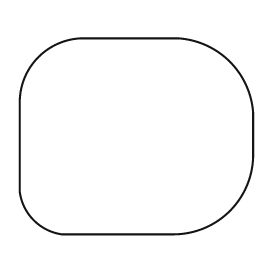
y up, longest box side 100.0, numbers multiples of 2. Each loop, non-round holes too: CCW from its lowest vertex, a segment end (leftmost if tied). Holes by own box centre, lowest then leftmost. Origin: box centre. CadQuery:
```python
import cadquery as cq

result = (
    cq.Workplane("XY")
    .moveTo(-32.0, -42.0)
    .lineTo(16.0, -42.0)
    .threePointArc((40.0, -32.0), (50.0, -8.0))
    .lineTo(50.0, 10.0)
    .threePointArc((40.0, 32.0), (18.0, 42.0))
    .lineTo(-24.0, 42.0)
    .threePointArc((-42.0, 34.0), (-50.0, 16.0))
    .lineTo(-50.0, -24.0)
    .threePointArc((-44.0, -36.0), (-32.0, -42.0))
    .close()
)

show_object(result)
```